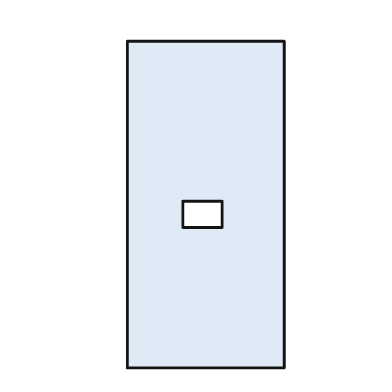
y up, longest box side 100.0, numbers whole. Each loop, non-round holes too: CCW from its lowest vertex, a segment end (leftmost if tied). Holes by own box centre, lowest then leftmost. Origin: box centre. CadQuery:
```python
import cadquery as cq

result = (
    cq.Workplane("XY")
    .moveTo(-24.0, -50.0)
    .lineTo(24.0, -50.0)
    .lineTo(24.0, 50.0)
    .lineTo(-24.0, 50.0)
    .close()
    .moveTo(-7.0, -7.0)
    .lineTo(5.0, -7.0)
    .lineTo(5.0, 1.0)
    .lineTo(-7.0, 1.0)
    .close()
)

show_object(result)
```